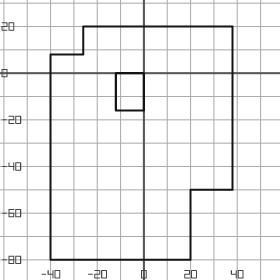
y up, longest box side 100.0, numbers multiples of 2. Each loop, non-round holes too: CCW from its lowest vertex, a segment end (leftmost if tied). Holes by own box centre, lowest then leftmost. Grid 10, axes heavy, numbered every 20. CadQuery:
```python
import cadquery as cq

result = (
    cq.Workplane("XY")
    .moveTo(-40.0, -80.0)
    .lineTo(20.0, -80.0)
    .lineTo(20.0, -50.0)
    .lineTo(38.0, -50.0)
    .lineTo(38.0, 20.0)
    .lineTo(-26.0, 20.0)
    .lineTo(-26.0, 8.0)
    .lineTo(-40.0, 8.0)
    .close()
    .moveTo(-12.0, -16.0)
    .lineTo(0.0, -16.0)
    .lineTo(0.0, 0.0)
    .lineTo(-12.0, 0.0)
    .close()
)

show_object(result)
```